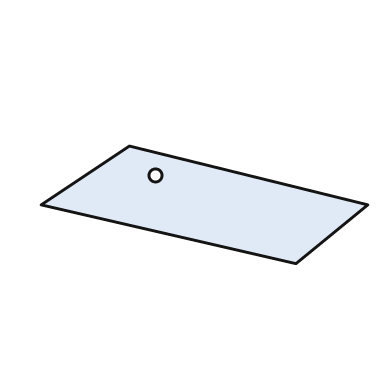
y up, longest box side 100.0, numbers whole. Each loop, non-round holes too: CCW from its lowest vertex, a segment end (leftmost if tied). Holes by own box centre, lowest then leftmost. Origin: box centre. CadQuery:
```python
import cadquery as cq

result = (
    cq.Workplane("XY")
    .moveTo(28.0, -18.0)
    .lineTo(50.0, 0.0)
    .lineTo(-23.0, 18.0)
    .lineTo(-50.0, 0.0)
    .close()
    .moveTo(-15.0, 9.0)
    .circle(2.0)
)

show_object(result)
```